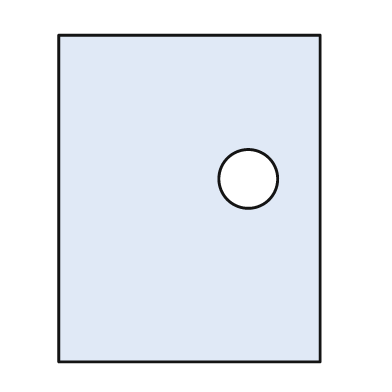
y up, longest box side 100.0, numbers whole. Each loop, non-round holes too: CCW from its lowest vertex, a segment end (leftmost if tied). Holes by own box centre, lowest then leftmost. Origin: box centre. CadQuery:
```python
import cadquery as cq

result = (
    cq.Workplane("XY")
    .moveTo(-40.0, -50.0)
    .lineTo(40.0, -50.0)
    .lineTo(40.0, 50.0)
    .lineTo(-40.0, 50.0)
    .close()
    .moveTo(18.0, 6.0)
    .circle(9.0)
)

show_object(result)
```